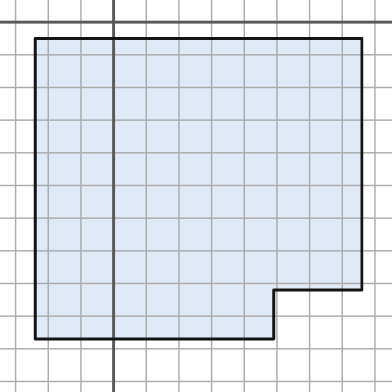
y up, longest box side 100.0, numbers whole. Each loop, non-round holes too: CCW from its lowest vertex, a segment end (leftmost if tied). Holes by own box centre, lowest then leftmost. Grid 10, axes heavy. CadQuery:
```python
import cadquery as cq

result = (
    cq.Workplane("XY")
    .moveTo(-24.0, -97.0)
    .lineTo(49.0, -97.0)
    .lineTo(49.0, -82.0)
    .lineTo(76.0, -82.0)
    .lineTo(76.0, -5.0)
    .lineTo(-24.0, -5.0)
    .close()
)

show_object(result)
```